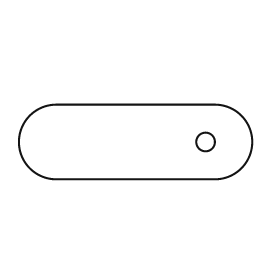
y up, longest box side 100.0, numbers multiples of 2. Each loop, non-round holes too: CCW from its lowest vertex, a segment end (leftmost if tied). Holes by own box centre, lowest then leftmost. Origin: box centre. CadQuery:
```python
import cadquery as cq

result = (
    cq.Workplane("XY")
    .moveTo(-34.0, -16.0)
    .lineTo(34.0, -16.0)
    .threePointArc((50.0, 0.0), (34.0, 16.0))
    .lineTo(-34.0, 16.0)
    .threePointArc((-50.0, 0.0), (-34.0, -16.0))
    .close()
    .moveTo(30.0, 0.0)
    .circle(4.0)
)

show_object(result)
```